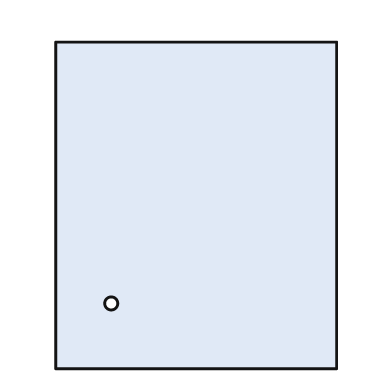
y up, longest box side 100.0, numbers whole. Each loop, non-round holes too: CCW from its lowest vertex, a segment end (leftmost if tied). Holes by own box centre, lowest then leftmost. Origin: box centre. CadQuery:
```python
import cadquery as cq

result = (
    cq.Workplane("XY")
    .moveTo(-43.0, -50.0)
    .lineTo(43.0, -50.0)
    .lineTo(43.0, 50.0)
    .lineTo(-43.0, 50.0)
    .close()
    .moveTo(-26.0, -30.0)
    .circle(2.0)
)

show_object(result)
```